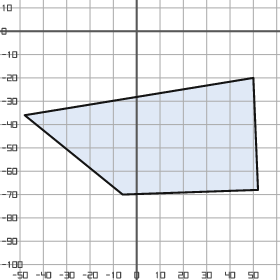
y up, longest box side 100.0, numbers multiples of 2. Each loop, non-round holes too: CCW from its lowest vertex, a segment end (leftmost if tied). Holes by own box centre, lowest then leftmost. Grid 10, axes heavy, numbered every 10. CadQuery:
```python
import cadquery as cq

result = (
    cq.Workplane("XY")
    .moveTo(-6.0, -70.0)
    .lineTo(52.0, -68.0)
    .lineTo(50.0, -20.0)
    .lineTo(-48.0, -36.0)
    .close()
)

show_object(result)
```